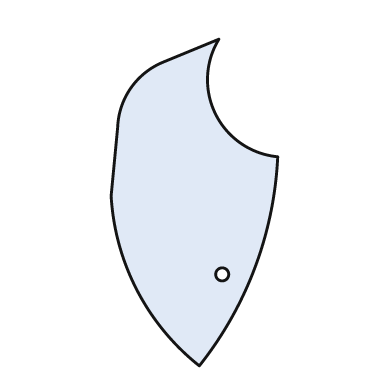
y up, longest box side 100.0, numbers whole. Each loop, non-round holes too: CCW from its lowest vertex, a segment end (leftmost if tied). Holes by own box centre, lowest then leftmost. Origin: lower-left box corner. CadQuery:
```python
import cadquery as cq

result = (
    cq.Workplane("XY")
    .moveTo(27.0, 0.0)
    .threePointArc((44.0, 30.0), (51.0, 64.0))
    .threePointArc((32.0, 77.0), (33.0, 100.0))
    .lineTo(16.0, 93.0)
    .threePointArc((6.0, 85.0), (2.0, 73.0))
    .lineTo(0.0, 52.0)
    .threePointArc((8.0, 23.0), (27.0, 0.0))
    .close()
    .moveTo(34.0, 28.0)
    .circle(2.0)
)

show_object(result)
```